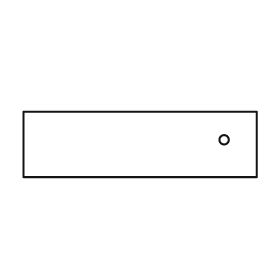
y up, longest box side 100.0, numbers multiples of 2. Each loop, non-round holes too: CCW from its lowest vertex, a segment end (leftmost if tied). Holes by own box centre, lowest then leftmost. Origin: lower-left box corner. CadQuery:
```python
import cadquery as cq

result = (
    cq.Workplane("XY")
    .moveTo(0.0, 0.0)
    .lineTo(100.0, 0.0)
    .lineTo(100.0, 28.0)
    .lineTo(0.0, 28.0)
    .close()
    .moveTo(86.0, 16.0)
    .circle(2.0)
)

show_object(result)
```